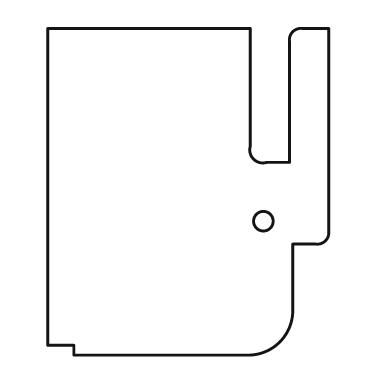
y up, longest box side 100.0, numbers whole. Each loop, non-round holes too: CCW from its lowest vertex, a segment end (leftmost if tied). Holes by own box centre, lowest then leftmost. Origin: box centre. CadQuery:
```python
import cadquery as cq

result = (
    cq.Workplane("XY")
    .moveTo(-35.0, -50.0)
    .lineTo(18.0, -50.0)
    .threePointArc((28.0, -46.0), (32.0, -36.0))
    .lineTo(32.0, -16.0)
    .lineTo(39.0, -16.0)
    .threePointArc((42.0, -15.0), (43.0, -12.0))
    .lineTo(43.0, 50.0)
    .lineTo(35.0, 50.0)
    .threePointArc((32.0, 49.0), (31.0, 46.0))
    .lineTo(31.0, 9.0)
    .lineTo(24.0, 9.0)
    .threePointArc((20.0, 10.0), (19.0, 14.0))
    .lineTo(19.0, 50.0)
    .lineTo(-43.0, 50.0)
    .lineTo(-43.0, -47.0)
    .lineTo(-35.0, -47.0)
    .close()
    .moveTo(23.0, -9.0)
    .circle(3.0)
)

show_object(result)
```